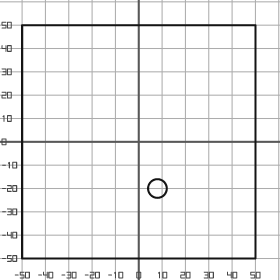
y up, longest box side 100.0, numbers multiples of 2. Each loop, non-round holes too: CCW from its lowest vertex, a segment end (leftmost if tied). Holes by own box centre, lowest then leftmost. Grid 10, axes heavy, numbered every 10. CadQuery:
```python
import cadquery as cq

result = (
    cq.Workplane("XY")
    .moveTo(-50.0, -50.0)
    .lineTo(50.0, -50.0)
    .lineTo(50.0, 50.0)
    .lineTo(-50.0, 50.0)
    .close()
    .moveTo(8.0, -20.0)
    .circle(4.0)
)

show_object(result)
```